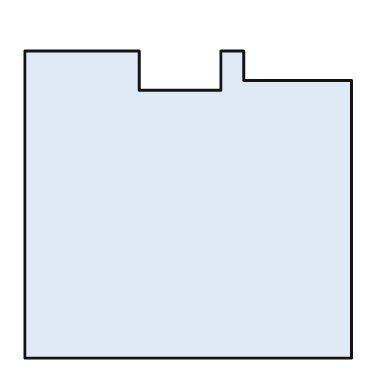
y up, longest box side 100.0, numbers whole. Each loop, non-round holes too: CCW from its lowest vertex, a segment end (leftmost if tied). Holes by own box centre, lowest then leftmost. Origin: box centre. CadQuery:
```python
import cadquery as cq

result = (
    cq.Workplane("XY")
    .moveTo(-50.0, -47.0)
    .lineTo(50.0, -47.0)
    .lineTo(50.0, 38.0)
    .lineTo(17.0, 38.0)
    .lineTo(17.0, 47.0)
    .lineTo(10.0, 47.0)
    .lineTo(10.0, 35.0)
    .lineTo(-15.0, 35.0)
    .lineTo(-15.0, 47.0)
    .lineTo(-50.0, 47.0)
    .close()
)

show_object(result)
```